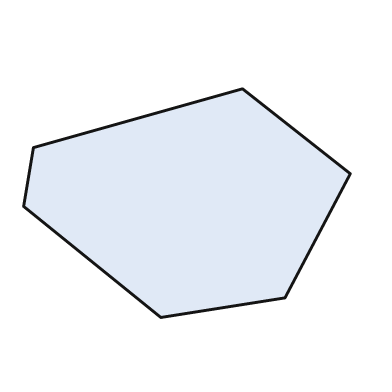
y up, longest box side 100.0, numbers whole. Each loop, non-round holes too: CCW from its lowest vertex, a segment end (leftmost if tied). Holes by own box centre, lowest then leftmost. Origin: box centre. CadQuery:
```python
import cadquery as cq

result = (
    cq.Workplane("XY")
    .moveTo(-8.0, -35.0)
    .lineTo(30.0, -29.0)
    .lineTo(50.0, 9.0)
    .lineTo(17.0, 35.0)
    .lineTo(-47.0, 17.0)
    .lineTo(-50.0, -1.0)
    .close()
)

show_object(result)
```